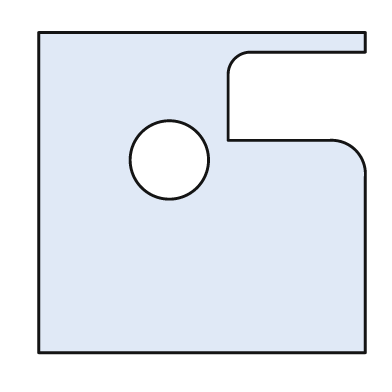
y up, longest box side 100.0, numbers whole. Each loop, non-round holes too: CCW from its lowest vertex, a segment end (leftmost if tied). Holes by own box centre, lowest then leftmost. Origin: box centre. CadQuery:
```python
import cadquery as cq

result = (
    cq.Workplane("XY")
    .moveTo(-50.0, -49.0)
    .lineTo(50.0, -49.0)
    .lineTo(50.0, 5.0)
    .threePointArc((47.0, 13.0), (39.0, 16.0))
    .lineTo(8.0, 16.0)
    .lineTo(8.0, 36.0)
    .threePointArc((10.0, 41.0), (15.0, 43.0))
    .lineTo(50.0, 43.0)
    .lineTo(50.0, 49.0)
    .lineTo(-50.0, 49.0)
    .close()
    .moveTo(-10.0, 10.0)
    .circle(12.0)
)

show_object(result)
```